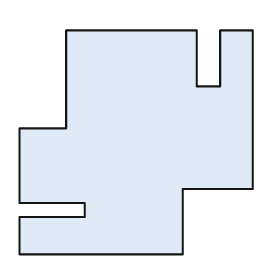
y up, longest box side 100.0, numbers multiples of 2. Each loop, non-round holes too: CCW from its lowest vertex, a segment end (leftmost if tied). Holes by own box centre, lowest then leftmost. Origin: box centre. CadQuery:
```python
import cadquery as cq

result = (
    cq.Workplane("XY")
    .moveTo(-50.0, -48.0)
    .lineTo(20.0, -48.0)
    .lineTo(20.0, -20.0)
    .lineTo(50.0, -20.0)
    .lineTo(50.0, 48.0)
    .lineTo(36.0, 48.0)
    .lineTo(36.0, 24.0)
    .lineTo(26.0, 24.0)
    .lineTo(26.0, 48.0)
    .lineTo(-30.0, 48.0)
    .lineTo(-30.0, 6.0)
    .lineTo(-50.0, 6.0)
    .lineTo(-50.0, -26.0)
    .lineTo(-22.0, -26.0)
    .lineTo(-22.0, -32.0)
    .lineTo(-50.0, -32.0)
    .close()
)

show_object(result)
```